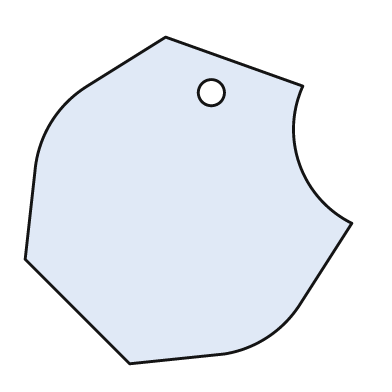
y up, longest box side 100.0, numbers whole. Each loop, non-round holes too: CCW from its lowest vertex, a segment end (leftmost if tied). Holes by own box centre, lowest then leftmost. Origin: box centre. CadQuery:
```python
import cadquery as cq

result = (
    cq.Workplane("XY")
    .moveTo(-18.0, -50.0)
    .lineTo(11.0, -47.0)
    .threePointArc((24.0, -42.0), (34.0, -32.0))
    .lineTo(50.0, -7.0)
    .threePointArc((34.0, 11.0), (35.0, 35.0))
    .lineTo(-7.0, 50.0)
    .lineTo(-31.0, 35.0)
    .threePointArc((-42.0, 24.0), (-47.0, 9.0))
    .lineTo(-50.0, -18.0)
    .close()
    .moveTo(7.0, 33.0)
    .circle(4.0)
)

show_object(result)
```